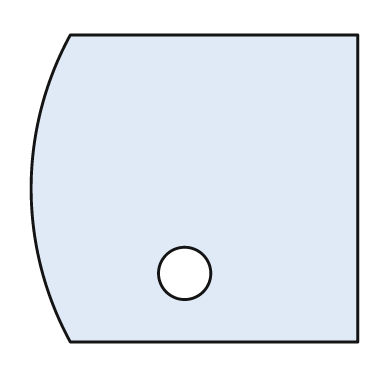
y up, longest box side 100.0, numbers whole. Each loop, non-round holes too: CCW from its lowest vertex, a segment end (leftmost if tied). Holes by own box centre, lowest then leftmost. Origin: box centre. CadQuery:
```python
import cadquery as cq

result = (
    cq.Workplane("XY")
    .moveTo(-38.0, -47.0)
    .lineTo(50.0, -47.0)
    .lineTo(50.0, 47.0)
    .lineTo(-38.0, 47.0)
    .threePointArc((-50.0, 0.0), (-38.0, -47.0))
    .close()
    .moveTo(-3.0, -26.0)
    .circle(8.0)
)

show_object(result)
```